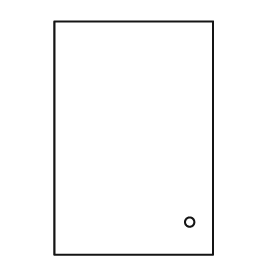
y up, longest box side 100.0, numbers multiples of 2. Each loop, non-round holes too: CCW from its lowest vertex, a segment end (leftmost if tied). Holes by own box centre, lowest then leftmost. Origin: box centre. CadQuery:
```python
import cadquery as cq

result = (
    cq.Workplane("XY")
    .moveTo(-34.0, -50.0)
    .lineTo(34.0, -50.0)
    .lineTo(34.0, 50.0)
    .lineTo(-34.0, 50.0)
    .close()
    .moveTo(24.0, -36.0)
    .circle(2.0)
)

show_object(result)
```